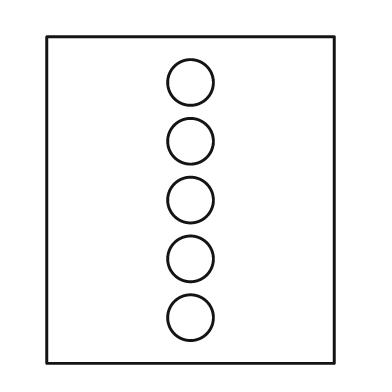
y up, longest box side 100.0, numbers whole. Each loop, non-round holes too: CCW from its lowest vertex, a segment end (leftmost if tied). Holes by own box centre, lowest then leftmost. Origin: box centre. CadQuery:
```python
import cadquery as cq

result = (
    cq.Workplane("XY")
    .moveTo(-44.0, -50.0)
    .lineTo(44.0, -50.0)
    .lineTo(44.0, 50.0)
    .lineTo(-44.0, 50.0)
    .close()
    .moveTo(0.0, -36.0)
    .circle(7.0)
    .moveTo(0.0, -18.0)
    .circle(7.0)
    .moveTo(0.0, 0.0)
    .circle(7.0)
    .moveTo(0.0, 18.0)
    .circle(7.0)
    .moveTo(0.0, 36.0)
    .circle(7.0)
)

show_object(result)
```